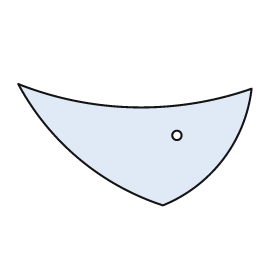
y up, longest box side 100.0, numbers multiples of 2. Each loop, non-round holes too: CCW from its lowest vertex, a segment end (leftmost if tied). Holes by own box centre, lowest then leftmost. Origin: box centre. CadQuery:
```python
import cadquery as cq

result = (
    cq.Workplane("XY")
    .moveTo(12.0, -26.0)
    .threePointArc((38.0, -6.0), (50.0, 24.0))
    .threePointArc((0.0, 16.0), (-50.0, 26.0))
    .threePointArc((-24.0, -6.0), (12.0, -26.0))
    .close()
    .moveTo(18.0, 4.0)
    .circle(2.0)
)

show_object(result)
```